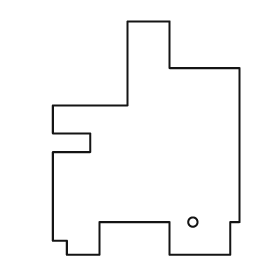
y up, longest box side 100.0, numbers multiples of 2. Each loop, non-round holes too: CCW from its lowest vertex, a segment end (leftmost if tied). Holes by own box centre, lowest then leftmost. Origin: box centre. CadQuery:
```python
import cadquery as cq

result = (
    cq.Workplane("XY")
    .moveTo(-34.0, -50.0)
    .lineTo(-20.0, -50.0)
    .lineTo(-20.0, -36.0)
    .lineTo(10.0, -36.0)
    .lineTo(10.0, -50.0)
    .lineTo(36.0, -50.0)
    .lineTo(36.0, -36.0)
    .lineTo(40.0, -36.0)
    .lineTo(40.0, 30.0)
    .lineTo(10.0, 30.0)
    .lineTo(10.0, 50.0)
    .lineTo(-8.0, 50.0)
    .lineTo(-8.0, 14.0)
    .lineTo(-40.0, 14.0)
    .lineTo(-40.0, 2.0)
    .lineTo(-24.0, 2.0)
    .lineTo(-24.0, -6.0)
    .lineTo(-40.0, -6.0)
    .lineTo(-40.0, -44.0)
    .lineTo(-34.0, -44.0)
    .close()
    .moveTo(20.0, -36.0)
    .circle(2.0)
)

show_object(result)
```